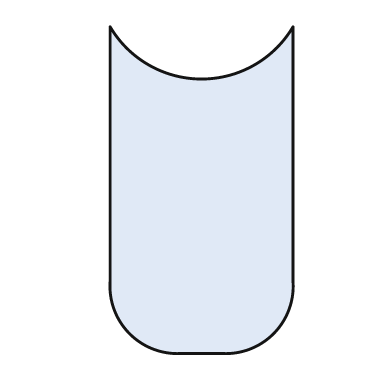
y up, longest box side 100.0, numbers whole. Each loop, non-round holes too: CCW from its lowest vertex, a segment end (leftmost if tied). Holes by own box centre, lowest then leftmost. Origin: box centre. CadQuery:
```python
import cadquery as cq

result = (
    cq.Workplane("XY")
    .moveTo(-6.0, -50.0)
    .lineTo(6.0, -50.0)
    .threePointArc((22.0, -44.0), (28.0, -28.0))
    .lineTo(28.0, 50.0)
    .threePointArc((0.0, 34.0), (-28.0, 50.0))
    .lineTo(-28.0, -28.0)
    .threePointArc((-22.0, -44.0), (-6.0, -50.0))
    .close()
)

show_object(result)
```